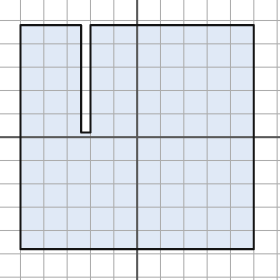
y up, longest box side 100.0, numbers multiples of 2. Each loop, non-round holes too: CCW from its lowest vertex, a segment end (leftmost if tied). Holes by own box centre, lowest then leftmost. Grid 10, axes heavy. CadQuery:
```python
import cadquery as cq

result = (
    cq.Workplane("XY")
    .moveTo(-50.0, -48.0)
    .lineTo(50.0, -48.0)
    .lineTo(50.0, 48.0)
    .lineTo(-20.0, 48.0)
    .lineTo(-20.0, 2.0)
    .lineTo(-24.0, 2.0)
    .lineTo(-24.0, 48.0)
    .lineTo(-50.0, 48.0)
    .close()
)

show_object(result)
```